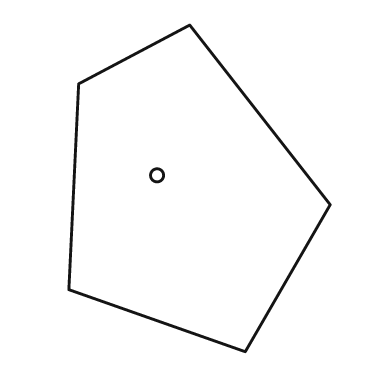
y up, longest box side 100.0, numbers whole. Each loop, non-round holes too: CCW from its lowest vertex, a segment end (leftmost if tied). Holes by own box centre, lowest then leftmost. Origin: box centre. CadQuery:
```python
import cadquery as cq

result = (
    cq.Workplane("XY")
    .moveTo(14.0, -50.0)
    .lineTo(40.0, -5.0)
    .lineTo(-3.0, 50.0)
    .lineTo(-37.0, 32.0)
    .lineTo(-40.0, -31.0)
    .close()
    .moveTo(-13.0, 4.0)
    .circle(2.0)
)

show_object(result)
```